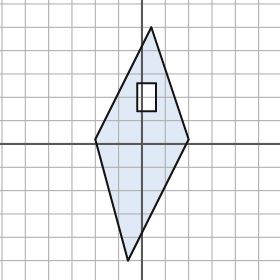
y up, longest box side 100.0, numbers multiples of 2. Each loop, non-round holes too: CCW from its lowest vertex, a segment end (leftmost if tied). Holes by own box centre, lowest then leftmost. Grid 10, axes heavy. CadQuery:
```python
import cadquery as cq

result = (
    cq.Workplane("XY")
    .moveTo(-6.0, -50.0)
    .lineTo(20.0, 2.0)
    .lineTo(4.0, 50.0)
    .lineTo(-20.0, 2.0)
    .close()
    .moveTo(-2.0, 14.0)
    .lineTo(6.0, 14.0)
    .lineTo(6.0, 26.0)
    .lineTo(-2.0, 26.0)
    .close()
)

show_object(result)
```